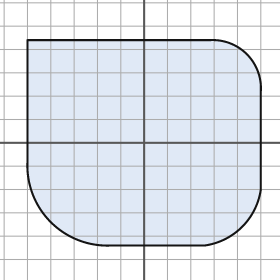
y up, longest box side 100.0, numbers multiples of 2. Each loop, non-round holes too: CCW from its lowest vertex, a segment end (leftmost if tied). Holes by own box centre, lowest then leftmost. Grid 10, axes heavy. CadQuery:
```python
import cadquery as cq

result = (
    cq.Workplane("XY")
    .moveTo(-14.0, -44.0)
    .lineTo(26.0, -44.0)
    .threePointArc((42.0, -36.0), (50.0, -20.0))
    .lineTo(50.0, 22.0)
    .threePointArc((44.0, 38.0), (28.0, 44.0))
    .lineTo(-50.0, 44.0)
    .lineTo(-50.0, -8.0)
    .threePointArc((-40.0, -34.0), (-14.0, -44.0))
    .close()
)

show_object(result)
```